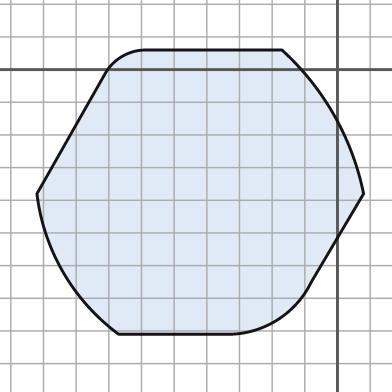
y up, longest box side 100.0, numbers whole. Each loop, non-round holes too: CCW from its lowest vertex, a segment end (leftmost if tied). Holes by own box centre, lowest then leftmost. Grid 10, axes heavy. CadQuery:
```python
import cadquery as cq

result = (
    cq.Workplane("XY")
    .moveTo(-67.0, -81.0)
    .lineTo(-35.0, -81.0)
    .threePointArc((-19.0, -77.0), (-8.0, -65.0))
    .lineTo(8.0, -38.0)
    .threePointArc((-1.0, -14.0), (-17.0, 6.0))
    .lineTo(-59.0, 6.0)
    .threePointArc((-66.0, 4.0), (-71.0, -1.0))
    .lineTo(-92.0, -38.0)
    .threePointArc((-84.0, -62.0), (-67.0, -81.0))
    .close()
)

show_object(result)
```